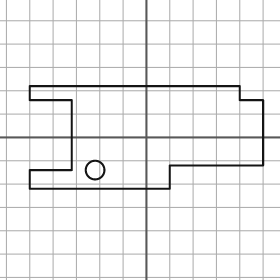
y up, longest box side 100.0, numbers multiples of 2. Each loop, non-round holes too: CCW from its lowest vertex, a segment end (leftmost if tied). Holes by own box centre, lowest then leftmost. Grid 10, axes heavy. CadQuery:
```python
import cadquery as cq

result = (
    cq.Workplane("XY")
    .moveTo(-50.0, -22.0)
    .lineTo(10.0, -22.0)
    .lineTo(10.0, -12.0)
    .lineTo(50.0, -12.0)
    .lineTo(50.0, 16.0)
    .lineTo(40.0, 16.0)
    .lineTo(40.0, 22.0)
    .lineTo(-50.0, 22.0)
    .lineTo(-50.0, 16.0)
    .lineTo(-32.0, 16.0)
    .lineTo(-32.0, -14.0)
    .lineTo(-50.0, -14.0)
    .close()
    .moveTo(-22.0, -14.0)
    .circle(4.0)
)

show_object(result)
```